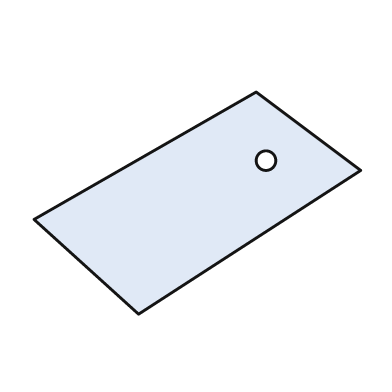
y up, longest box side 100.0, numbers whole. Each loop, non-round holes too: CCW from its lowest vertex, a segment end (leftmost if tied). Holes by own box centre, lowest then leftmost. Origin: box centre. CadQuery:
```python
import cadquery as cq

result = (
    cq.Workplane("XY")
    .moveTo(-18.0, -34.0)
    .lineTo(50.0, 10.0)
    .lineTo(18.0, 34.0)
    .lineTo(-50.0, -5.0)
    .close()
    .moveTo(21.0, 13.0)
    .circle(3.0)
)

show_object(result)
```